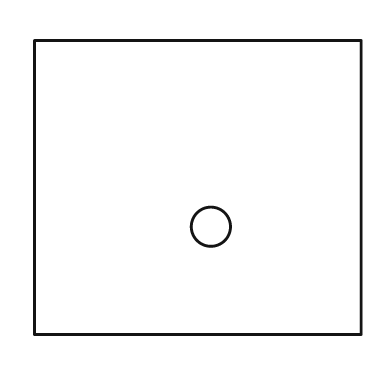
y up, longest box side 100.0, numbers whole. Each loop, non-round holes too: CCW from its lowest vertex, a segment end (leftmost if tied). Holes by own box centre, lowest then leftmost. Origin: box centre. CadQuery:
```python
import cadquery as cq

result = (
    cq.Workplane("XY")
    .moveTo(-50.0, -45.0)
    .lineTo(50.0, -45.0)
    .lineTo(50.0, 45.0)
    .lineTo(-50.0, 45.0)
    .close()
    .moveTo(4.0, -12.0)
    .circle(6.0)
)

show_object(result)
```